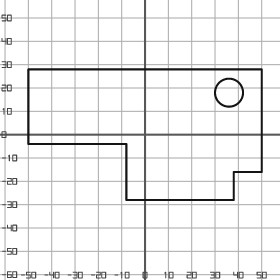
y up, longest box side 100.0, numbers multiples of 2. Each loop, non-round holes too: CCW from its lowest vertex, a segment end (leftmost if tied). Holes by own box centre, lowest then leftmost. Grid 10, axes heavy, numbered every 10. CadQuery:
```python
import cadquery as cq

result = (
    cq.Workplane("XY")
    .moveTo(-8.0, -28.0)
    .lineTo(38.0, -28.0)
    .lineTo(38.0, -16.0)
    .lineTo(50.0, -16.0)
    .lineTo(50.0, 28.0)
    .lineTo(-50.0, 28.0)
    .lineTo(-50.0, -4.0)
    .lineTo(-8.0, -4.0)
    .close()
    .moveTo(36.0, 18.0)
    .circle(6.0)
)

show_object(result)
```